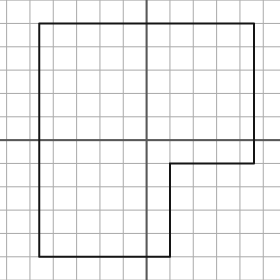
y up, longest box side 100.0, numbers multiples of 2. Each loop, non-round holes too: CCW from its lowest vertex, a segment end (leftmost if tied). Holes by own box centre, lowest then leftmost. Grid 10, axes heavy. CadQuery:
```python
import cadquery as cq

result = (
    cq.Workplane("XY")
    .moveTo(-46.0, -50.0)
    .lineTo(10.0, -50.0)
    .lineTo(10.0, -10.0)
    .lineTo(46.0, -10.0)
    .lineTo(46.0, 50.0)
    .lineTo(-46.0, 50.0)
    .close()
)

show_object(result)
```